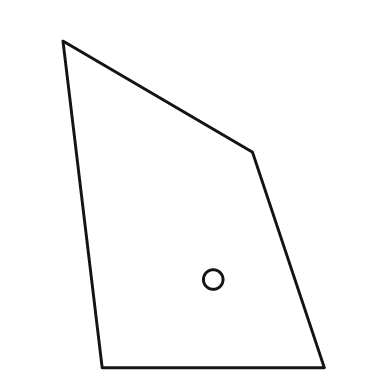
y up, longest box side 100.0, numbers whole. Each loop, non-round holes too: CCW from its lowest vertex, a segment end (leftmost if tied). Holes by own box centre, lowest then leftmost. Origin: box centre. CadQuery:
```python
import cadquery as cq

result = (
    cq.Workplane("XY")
    .moveTo(-28.0, -50.0)
    .lineTo(40.0, -50.0)
    .lineTo(18.0, 16.0)
    .lineTo(-40.0, 50.0)
    .close()
    .moveTo(6.0, -23.0)
    .circle(3.0)
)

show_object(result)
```